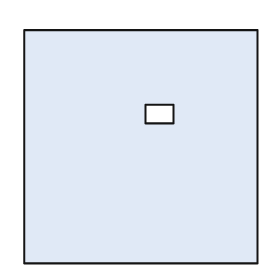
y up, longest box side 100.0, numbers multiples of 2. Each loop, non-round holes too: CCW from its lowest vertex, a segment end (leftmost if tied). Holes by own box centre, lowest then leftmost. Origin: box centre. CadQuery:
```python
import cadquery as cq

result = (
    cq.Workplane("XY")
    .moveTo(-50.0, -50.0)
    .lineTo(50.0, -50.0)
    .lineTo(50.0, 50.0)
    .lineTo(-50.0, 50.0)
    .close()
    .moveTo(2.0, 10.0)
    .lineTo(14.0, 10.0)
    .lineTo(14.0, 18.0)
    .lineTo(2.0, 18.0)
    .close()
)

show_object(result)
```